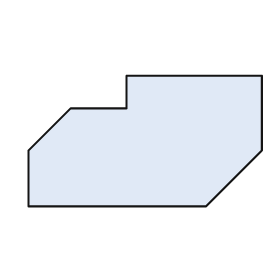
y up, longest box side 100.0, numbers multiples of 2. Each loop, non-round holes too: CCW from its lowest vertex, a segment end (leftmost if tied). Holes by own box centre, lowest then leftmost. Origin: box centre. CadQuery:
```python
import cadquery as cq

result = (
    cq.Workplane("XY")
    .moveTo(-50.0, -28.0)
    .lineTo(26.0, -28.0)
    .lineTo(50.0, -4.0)
    .lineTo(50.0, 28.0)
    .lineTo(-8.0, 28.0)
    .lineTo(-8.0, 14.0)
    .lineTo(-32.0, 14.0)
    .lineTo(-50.0, -4.0)
    .close()
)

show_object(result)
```